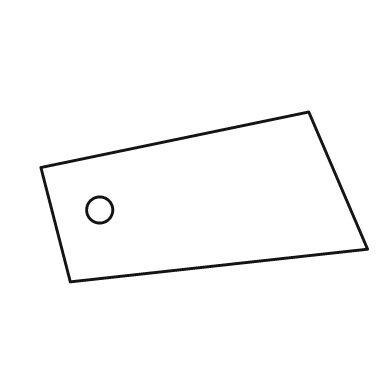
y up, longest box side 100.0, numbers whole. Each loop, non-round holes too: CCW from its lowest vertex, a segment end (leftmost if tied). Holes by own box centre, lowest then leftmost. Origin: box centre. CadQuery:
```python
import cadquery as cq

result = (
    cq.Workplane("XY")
    .moveTo(-41.0, -26.0)
    .lineTo(50.0, -16.0)
    .lineTo(32.0, 26.0)
    .lineTo(-50.0, 9.0)
    .close()
    .moveTo(-32.0, -4.0)
    .circle(4.0)
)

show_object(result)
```